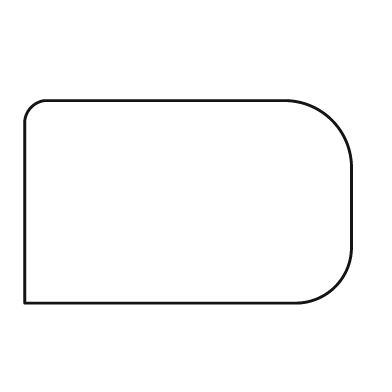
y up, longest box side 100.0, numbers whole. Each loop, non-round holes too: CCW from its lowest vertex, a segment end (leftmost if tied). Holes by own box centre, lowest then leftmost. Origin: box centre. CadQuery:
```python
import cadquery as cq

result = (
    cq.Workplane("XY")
    .moveTo(-50.0, -31.0)
    .lineTo(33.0, -31.0)
    .threePointArc((45.0, -26.0), (50.0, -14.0))
    .lineTo(50.0, 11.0)
    .threePointArc((44.0, 25.0), (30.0, 31.0))
    .lineTo(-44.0, 31.0)
    .threePointArc((-48.0, 29.0), (-50.0, 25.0))
    .close()
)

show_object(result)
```